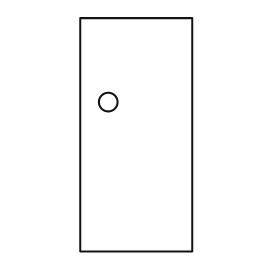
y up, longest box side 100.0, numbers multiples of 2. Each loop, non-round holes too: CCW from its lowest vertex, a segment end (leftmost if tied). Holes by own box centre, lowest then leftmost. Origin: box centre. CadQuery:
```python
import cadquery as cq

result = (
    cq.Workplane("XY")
    .moveTo(-24.0, -50.0)
    .lineTo(24.0, -50.0)
    .lineTo(24.0, 50.0)
    .lineTo(-24.0, 50.0)
    .close()
    .moveTo(-12.0, 14.0)
    .circle(4.0)
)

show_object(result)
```